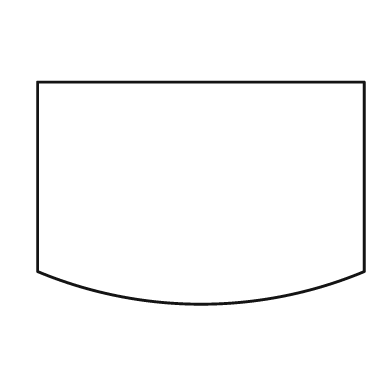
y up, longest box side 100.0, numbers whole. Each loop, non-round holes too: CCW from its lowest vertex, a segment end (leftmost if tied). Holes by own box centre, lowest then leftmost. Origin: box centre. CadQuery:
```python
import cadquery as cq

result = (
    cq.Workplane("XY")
    .moveTo(-50.0, -24.0)
    .threePointArc((0.0, -34.0), (50.0, -24.0))
    .lineTo(50.0, 34.0)
    .lineTo(-50.0, 34.0)
    .close()
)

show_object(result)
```